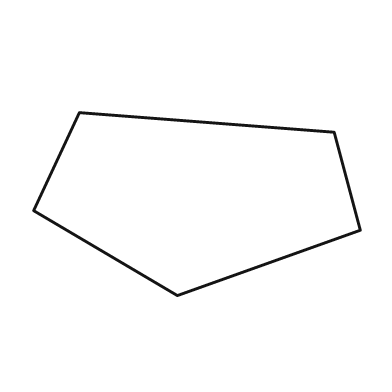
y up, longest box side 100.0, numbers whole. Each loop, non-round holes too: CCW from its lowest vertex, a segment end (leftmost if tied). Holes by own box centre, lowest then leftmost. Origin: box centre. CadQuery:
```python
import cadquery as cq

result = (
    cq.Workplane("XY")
    .moveTo(-6.0, -28.0)
    .lineTo(50.0, -8.0)
    .lineTo(42.0, 22.0)
    .lineTo(-36.0, 28.0)
    .lineTo(-50.0, -2.0)
    .close()
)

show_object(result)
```